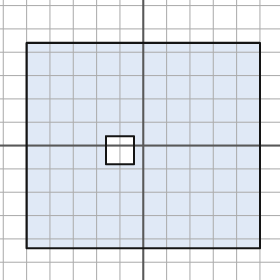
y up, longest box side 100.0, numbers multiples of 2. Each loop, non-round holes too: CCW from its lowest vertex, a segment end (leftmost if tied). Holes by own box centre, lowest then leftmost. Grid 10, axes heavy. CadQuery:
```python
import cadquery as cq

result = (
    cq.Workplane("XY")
    .moveTo(-50.0, -44.0)
    .lineTo(50.0, -44.0)
    .lineTo(50.0, 44.0)
    .lineTo(-50.0, 44.0)
    .close()
    .moveTo(-16.0, -8.0)
    .lineTo(-4.0, -8.0)
    .lineTo(-4.0, 4.0)
    .lineTo(-16.0, 4.0)
    .close()
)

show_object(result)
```